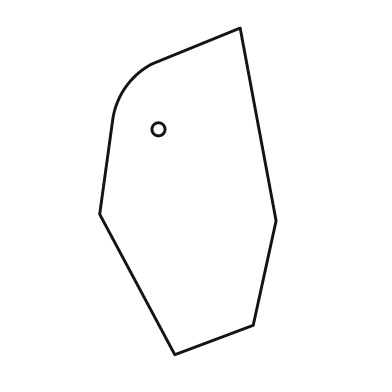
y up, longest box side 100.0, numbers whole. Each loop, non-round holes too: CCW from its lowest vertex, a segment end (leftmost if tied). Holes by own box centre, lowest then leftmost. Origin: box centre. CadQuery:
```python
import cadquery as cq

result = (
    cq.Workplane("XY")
    .moveTo(-4.0, -50.0)
    .lineTo(20.0, -41.0)
    .lineTo(27.0, -9.0)
    .lineTo(16.0, 50.0)
    .lineTo(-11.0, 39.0)
    .threePointArc((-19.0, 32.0), (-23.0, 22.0))
    .lineTo(-27.0, -7.0)
    .close()
    .moveTo(-9.0, 19.0)
    .circle(2.0)
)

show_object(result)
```